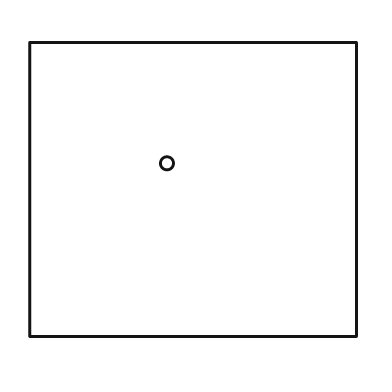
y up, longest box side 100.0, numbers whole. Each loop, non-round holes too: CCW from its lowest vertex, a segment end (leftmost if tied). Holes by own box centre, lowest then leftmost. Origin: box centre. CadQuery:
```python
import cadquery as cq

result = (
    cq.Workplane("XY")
    .moveTo(-50.0, -45.0)
    .lineTo(50.0, -45.0)
    .lineTo(50.0, 45.0)
    .lineTo(-50.0, 45.0)
    .close()
    .moveTo(-8.0, 8.0)
    .circle(2.0)
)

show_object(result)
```